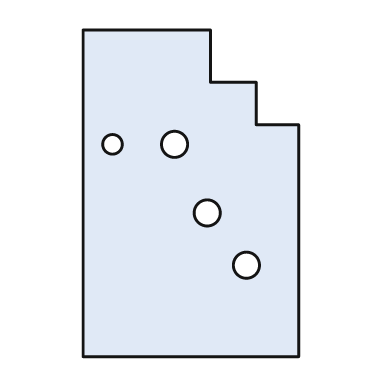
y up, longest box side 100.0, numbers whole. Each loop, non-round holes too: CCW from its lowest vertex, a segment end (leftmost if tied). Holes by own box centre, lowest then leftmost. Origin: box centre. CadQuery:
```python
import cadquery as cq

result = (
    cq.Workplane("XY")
    .moveTo(-33.0, -50.0)
    .lineTo(33.0, -50.0)
    .lineTo(33.0, 21.0)
    .lineTo(20.0, 21.0)
    .lineTo(20.0, 34.0)
    .lineTo(6.0, 34.0)
    .lineTo(6.0, 50.0)
    .lineTo(-33.0, 50.0)
    .close()
    .moveTo(17.0, -22.0)
    .circle(4.0)
    .moveTo(5.0, -6.0)
    .circle(4.0)
    .moveTo(-24.0, 15.0)
    .circle(3.0)
    .moveTo(-5.0, 15.0)
    .circle(4.0)
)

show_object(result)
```